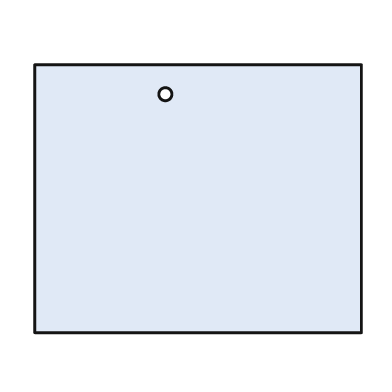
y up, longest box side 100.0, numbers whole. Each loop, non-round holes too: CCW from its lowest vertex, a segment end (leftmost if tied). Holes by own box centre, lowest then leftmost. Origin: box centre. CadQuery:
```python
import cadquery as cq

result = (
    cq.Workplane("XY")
    .moveTo(-50.0, -41.0)
    .lineTo(50.0, -41.0)
    .lineTo(50.0, 41.0)
    .lineTo(-50.0, 41.0)
    .close()
    .moveTo(-10.0, 32.0)
    .circle(2.0)
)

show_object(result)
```